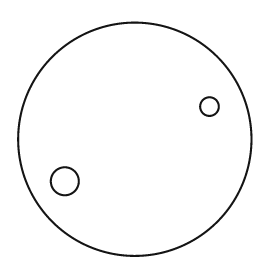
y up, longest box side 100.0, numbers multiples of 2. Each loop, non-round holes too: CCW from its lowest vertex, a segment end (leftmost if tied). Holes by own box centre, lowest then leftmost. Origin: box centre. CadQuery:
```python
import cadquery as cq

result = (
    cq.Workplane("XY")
    .moveTo(0.0, 0.0)
    .circle(50.0)
    .moveTo(-30.0, -18.0)
    .circle(6.0)
    .moveTo(32.0, 14.0)
    .circle(4.0)
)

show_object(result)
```